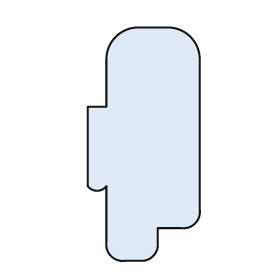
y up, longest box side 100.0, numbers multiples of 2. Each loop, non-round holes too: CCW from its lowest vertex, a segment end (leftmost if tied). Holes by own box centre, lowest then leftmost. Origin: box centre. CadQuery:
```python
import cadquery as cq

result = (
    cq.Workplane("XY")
    .moveTo(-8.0, -50.0)
    .lineTo(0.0, -50.0)
    .threePointArc((4.0, -48.0), (6.0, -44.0))
    .lineTo(6.0, -36.0)
    .lineTo(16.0, -36.0)
    .threePointArc((22.0, -34.0), (24.0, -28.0))
    .lineTo(24.0, 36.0)
    .threePointArc((20.0, 46.0), (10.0, 50.0))
    .lineTo(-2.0, 50.0)
    .threePointArc((-12.0, 46.0), (-16.0, 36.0))
    .lineTo(-16.0, 16.0)
    .lineTo(-24.0, 16.0)
    .lineTo(-24.0, -18.0)
    .threePointArc((-20.0, -20.0), (-16.0, -18.0))
    .lineTo(-16.0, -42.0)
    .threePointArc((-14.0, -48.0), (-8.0, -50.0))
    .close()
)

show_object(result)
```